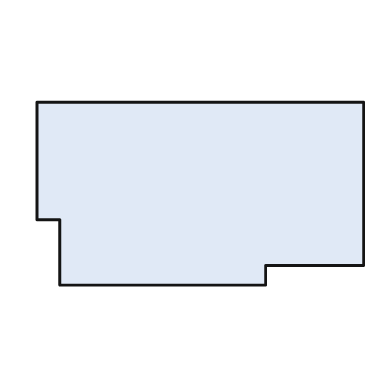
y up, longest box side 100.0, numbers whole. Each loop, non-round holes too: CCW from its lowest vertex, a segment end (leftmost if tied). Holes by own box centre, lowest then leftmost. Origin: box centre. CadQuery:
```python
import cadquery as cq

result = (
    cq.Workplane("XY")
    .moveTo(-43.0, -28.0)
    .lineTo(20.0, -28.0)
    .lineTo(20.0, -22.0)
    .lineTo(50.0, -22.0)
    .lineTo(50.0, 28.0)
    .lineTo(-50.0, 28.0)
    .lineTo(-50.0, -8.0)
    .lineTo(-43.0, -8.0)
    .close()
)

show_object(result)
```